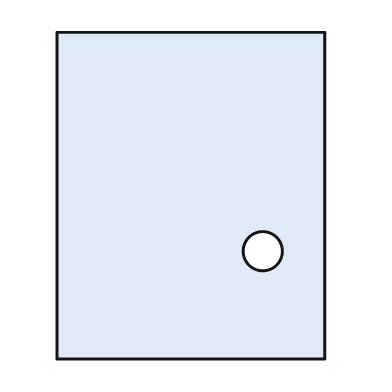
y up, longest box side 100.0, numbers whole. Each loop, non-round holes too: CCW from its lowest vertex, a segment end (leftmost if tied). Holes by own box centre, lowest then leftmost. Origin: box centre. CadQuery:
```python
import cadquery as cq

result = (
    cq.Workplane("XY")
    .moveTo(-41.0, -50.0)
    .lineTo(41.0, -50.0)
    .lineTo(41.0, 50.0)
    .lineTo(-41.0, 50.0)
    .close()
    .moveTo(22.0, -17.0)
    .circle(6.0)
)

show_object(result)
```